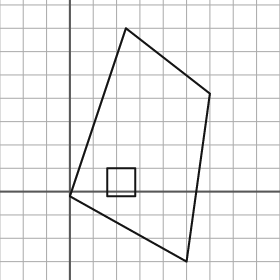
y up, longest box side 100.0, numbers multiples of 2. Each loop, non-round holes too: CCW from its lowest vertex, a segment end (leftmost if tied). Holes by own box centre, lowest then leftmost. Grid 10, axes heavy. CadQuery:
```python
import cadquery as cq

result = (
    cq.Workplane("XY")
    .moveTo(50.0, -30.0)
    .lineTo(60.0, 42.0)
    .lineTo(24.0, 70.0)
    .lineTo(0.0, -2.0)
    .close()
    .moveTo(16.0, -2.0)
    .lineTo(28.0, -2.0)
    .lineTo(28.0, 10.0)
    .lineTo(16.0, 10.0)
    .close()
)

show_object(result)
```